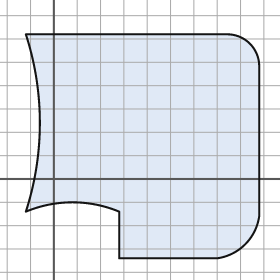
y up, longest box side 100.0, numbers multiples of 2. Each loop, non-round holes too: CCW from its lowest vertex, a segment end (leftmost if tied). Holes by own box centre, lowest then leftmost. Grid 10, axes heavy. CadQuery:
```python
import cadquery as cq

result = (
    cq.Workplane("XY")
    .moveTo(28.0, -34.0)
    .lineTo(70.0, -34.0)
    .threePointArc((82.0, -28.0), (88.0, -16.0))
    .lineTo(88.0, 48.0)
    .threePointArc((84.0, 58.0), (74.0, 62.0))
    .lineTo(-12.0, 62.0)
    .threePointArc((-6.0, 24.0), (-12.0, -14.0))
    .threePointArc((8.0, -10.0), (28.0, -14.0))
    .close()
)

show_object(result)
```